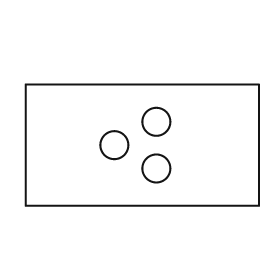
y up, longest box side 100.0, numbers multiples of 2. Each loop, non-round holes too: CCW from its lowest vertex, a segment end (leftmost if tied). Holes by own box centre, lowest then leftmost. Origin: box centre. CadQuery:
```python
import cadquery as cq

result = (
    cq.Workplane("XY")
    .moveTo(-50.0, -26.0)
    .lineTo(50.0, -26.0)
    .lineTo(50.0, 26.0)
    .lineTo(-50.0, 26.0)
    .close()
    .moveTo(6.0, -10.0)
    .circle(6.0)
    .moveTo(-12.0, 0.0)
    .circle(6.0)
    .moveTo(6.0, 10.0)
    .circle(6.0)
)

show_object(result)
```